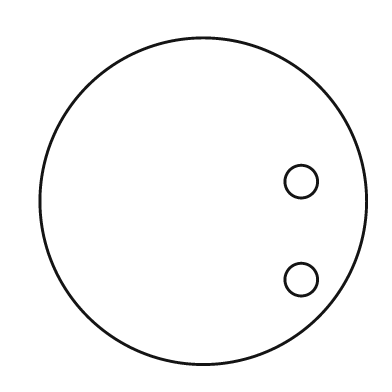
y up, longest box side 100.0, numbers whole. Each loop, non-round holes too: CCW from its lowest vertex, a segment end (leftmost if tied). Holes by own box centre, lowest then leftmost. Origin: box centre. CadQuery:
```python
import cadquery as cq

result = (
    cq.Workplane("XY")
    .moveTo(0.0, 0.0)
    .circle(50.0)
    .moveTo(30.0, -24.0)
    .circle(5.0)
    .moveTo(30.0, 6.0)
    .circle(5.0)
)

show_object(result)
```